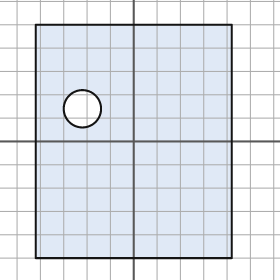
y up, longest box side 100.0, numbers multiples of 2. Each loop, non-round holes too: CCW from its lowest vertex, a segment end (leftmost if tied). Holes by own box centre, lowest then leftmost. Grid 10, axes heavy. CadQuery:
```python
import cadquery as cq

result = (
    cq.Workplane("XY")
    .moveTo(-42.0, -50.0)
    .lineTo(42.0, -50.0)
    .lineTo(42.0, 50.0)
    .lineTo(-42.0, 50.0)
    .close()
    .moveTo(-22.0, 14.0)
    .circle(8.0)
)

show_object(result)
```